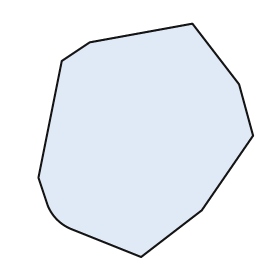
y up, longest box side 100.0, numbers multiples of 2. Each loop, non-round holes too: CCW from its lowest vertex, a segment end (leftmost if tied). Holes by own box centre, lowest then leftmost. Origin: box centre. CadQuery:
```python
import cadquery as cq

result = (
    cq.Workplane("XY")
    .moveTo(-2.0, -50.0)
    .lineTo(24.0, -30.0)
    .lineTo(46.0, 2.0)
    .lineTo(40.0, 24.0)
    .lineTo(20.0, 50.0)
    .lineTo(-24.0, 42.0)
    .lineTo(-36.0, 34.0)
    .lineTo(-46.0, -16.0)
    .lineTo(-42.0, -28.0)
    .threePointArc((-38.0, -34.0), (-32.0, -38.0))
    .close()
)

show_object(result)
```